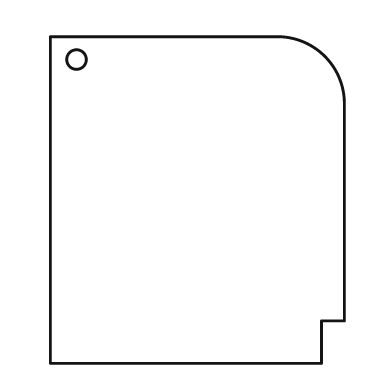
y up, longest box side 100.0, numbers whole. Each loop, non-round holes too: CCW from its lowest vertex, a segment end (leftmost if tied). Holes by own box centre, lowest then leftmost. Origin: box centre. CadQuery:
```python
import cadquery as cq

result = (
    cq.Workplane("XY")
    .moveTo(-45.0, -50.0)
    .lineTo(38.0, -50.0)
    .lineTo(38.0, -37.0)
    .lineTo(45.0, -37.0)
    .lineTo(45.0, 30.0)
    .threePointArc((39.0, 44.0), (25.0, 50.0))
    .lineTo(-45.0, 50.0)
    .close()
    .moveTo(-37.0, 43.0)
    .circle(3.0)
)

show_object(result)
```